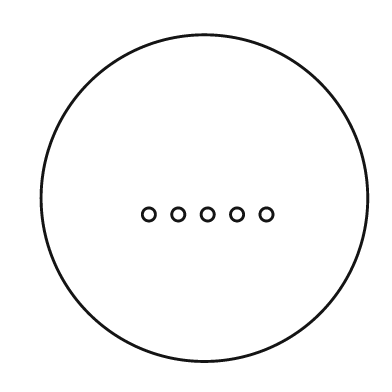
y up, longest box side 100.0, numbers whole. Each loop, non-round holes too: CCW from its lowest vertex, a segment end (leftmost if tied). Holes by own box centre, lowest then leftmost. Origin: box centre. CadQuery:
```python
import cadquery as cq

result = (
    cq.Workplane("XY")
    .moveTo(0.0, 0.0)
    .circle(50.0)
    .moveTo(-17.0, -5.0)
    .circle(2.0)
    .moveTo(-8.0, -5.0)
    .circle(2.0)
    .moveTo(1.0, -5.0)
    .circle(2.0)
    .moveTo(10.0, -5.0)
    .circle(2.0)
    .moveTo(19.0, -5.0)
    .circle(2.0)
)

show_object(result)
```